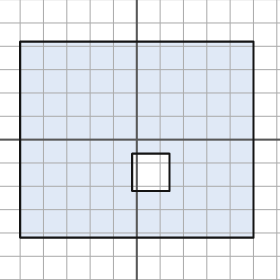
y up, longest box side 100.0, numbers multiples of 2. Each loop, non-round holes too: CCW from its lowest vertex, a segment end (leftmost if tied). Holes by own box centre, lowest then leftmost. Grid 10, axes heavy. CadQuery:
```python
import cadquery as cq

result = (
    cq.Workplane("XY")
    .moveTo(-50.0, -42.0)
    .lineTo(50.0, -42.0)
    .lineTo(50.0, 42.0)
    .lineTo(-50.0, 42.0)
    .close()
    .moveTo(-2.0, -22.0)
    .lineTo(14.0, -22.0)
    .lineTo(14.0, -6.0)
    .lineTo(-2.0, -6.0)
    .close()
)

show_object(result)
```